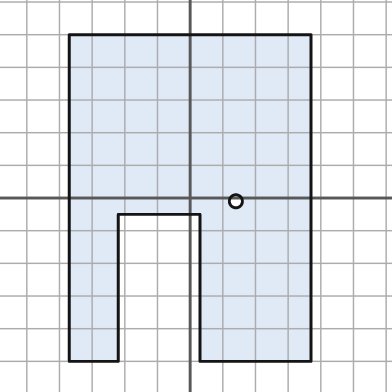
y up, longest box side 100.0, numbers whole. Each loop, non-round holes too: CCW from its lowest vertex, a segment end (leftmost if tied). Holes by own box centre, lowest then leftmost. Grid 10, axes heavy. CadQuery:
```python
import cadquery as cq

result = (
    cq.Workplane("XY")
    .moveTo(-37.0, -50.0)
    .lineTo(-22.0, -50.0)
    .lineTo(-22.0, -5.0)
    .lineTo(3.0, -5.0)
    .lineTo(3.0, -50.0)
    .lineTo(37.0, -50.0)
    .lineTo(37.0, 50.0)
    .lineTo(-37.0, 50.0)
    .close()
    .moveTo(14.0, -1.0)
    .circle(2.0)
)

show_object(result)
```